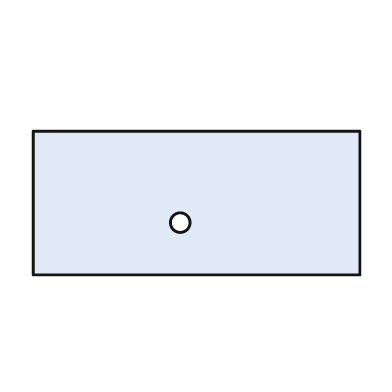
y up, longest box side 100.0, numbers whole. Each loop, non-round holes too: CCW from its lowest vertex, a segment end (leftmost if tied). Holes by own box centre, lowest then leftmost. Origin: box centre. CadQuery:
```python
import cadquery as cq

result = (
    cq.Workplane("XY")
    .moveTo(-50.0, -22.0)
    .lineTo(50.0, -22.0)
    .lineTo(50.0, 22.0)
    .lineTo(-50.0, 22.0)
    .close()
    .moveTo(-5.0, -6.0)
    .circle(3.0)
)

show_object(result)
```